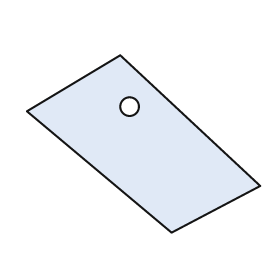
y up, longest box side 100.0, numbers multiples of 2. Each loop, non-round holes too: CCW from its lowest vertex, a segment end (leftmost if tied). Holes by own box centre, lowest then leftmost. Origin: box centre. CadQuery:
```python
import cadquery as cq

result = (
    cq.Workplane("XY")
    .moveTo(12.0, -38.0)
    .lineTo(50.0, -18.0)
    .lineTo(-10.0, 38.0)
    .lineTo(-50.0, 14.0)
    .close()
    .moveTo(-6.0, 16.0)
    .circle(4.0)
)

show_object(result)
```